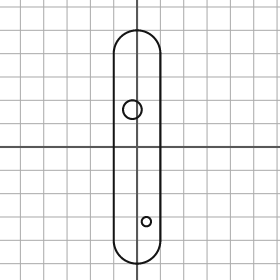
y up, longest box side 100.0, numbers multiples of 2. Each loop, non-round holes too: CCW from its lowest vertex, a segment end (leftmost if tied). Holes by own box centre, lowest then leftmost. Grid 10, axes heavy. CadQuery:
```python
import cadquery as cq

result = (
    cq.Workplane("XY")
    .moveTo(-10.0, -40.0)
    .threePointArc((0.0, -50.0), (10.0, -40.0))
    .lineTo(10.0, 40.0)
    .threePointArc((0.0, 50.0), (-10.0, 40.0))
    .close()
    .moveTo(4.0, -32.0)
    .circle(2.0)
    .moveTo(-2.0, 16.0)
    .circle(4.0)
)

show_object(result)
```